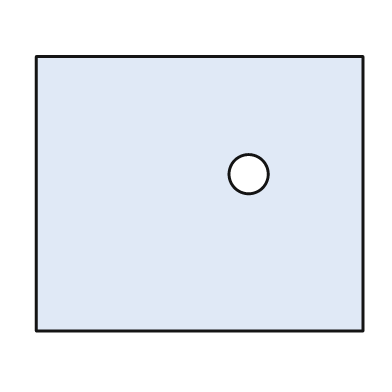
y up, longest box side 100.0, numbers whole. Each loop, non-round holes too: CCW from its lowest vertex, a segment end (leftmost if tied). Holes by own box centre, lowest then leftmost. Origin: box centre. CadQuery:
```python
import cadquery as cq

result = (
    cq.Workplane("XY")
    .moveTo(-50.0, -42.0)
    .lineTo(50.0, -42.0)
    .lineTo(50.0, 42.0)
    .lineTo(-50.0, 42.0)
    .close()
    .moveTo(15.0, 6.0)
    .circle(6.0)
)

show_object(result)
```